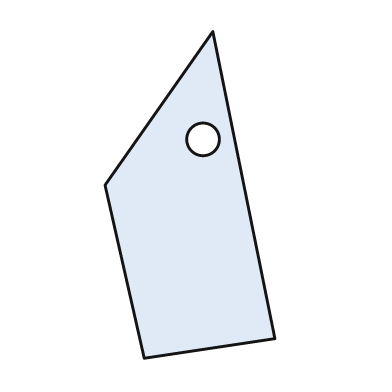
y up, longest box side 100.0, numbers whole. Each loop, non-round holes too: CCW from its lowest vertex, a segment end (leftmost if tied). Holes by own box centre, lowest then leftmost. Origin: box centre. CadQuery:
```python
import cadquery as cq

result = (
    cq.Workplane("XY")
    .moveTo(-14.0, -50.0)
    .lineTo(26.0, -44.0)
    .lineTo(7.0, 50.0)
    .lineTo(-26.0, 3.0)
    .close()
    .moveTo(4.0, 17.0)
    .circle(5.0)
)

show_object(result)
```